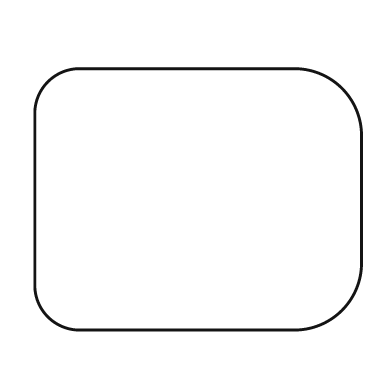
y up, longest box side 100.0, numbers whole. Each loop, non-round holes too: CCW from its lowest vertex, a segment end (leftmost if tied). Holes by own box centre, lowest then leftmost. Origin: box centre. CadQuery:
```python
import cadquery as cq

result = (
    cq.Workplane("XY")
    .moveTo(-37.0, -40.0)
    .lineTo(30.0, -40.0)
    .threePointArc((44.0, -34.0), (50.0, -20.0))
    .lineTo(50.0, 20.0)
    .threePointArc((44.0, 34.0), (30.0, 40.0))
    .lineTo(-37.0, 40.0)
    .threePointArc((-46.0, 36.0), (-50.0, 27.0))
    .lineTo(-50.0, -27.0)
    .threePointArc((-46.0, -36.0), (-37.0, -40.0))
    .close()
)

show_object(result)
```